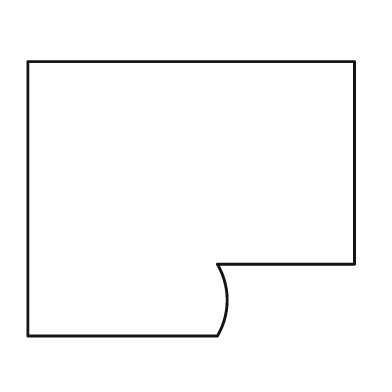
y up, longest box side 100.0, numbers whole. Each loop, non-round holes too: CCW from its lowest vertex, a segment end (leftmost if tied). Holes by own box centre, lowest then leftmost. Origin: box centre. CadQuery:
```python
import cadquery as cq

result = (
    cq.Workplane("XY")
    .moveTo(-50.0, -42.0)
    .lineTo(8.0, -42.0)
    .threePointArc((11.0, -31.0), (8.0, -20.0))
    .lineTo(50.0, -20.0)
    .lineTo(50.0, 42.0)
    .lineTo(-50.0, 42.0)
    .close()
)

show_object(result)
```